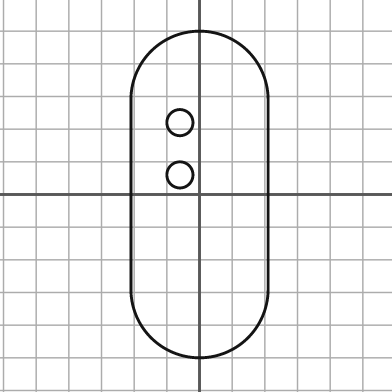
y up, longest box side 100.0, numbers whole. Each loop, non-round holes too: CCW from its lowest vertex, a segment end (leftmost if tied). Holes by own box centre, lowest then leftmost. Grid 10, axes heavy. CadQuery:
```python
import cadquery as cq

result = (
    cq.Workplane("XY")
    .moveTo(-21.0, -29.0)
    .threePointArc((0.0, -50.0), (21.0, -29.0))
    .lineTo(21.0, 29.0)
    .threePointArc((0.0, 50.0), (-21.0, 29.0))
    .close()
    .moveTo(-6.0, 6.0)
    .circle(4.0)
    .moveTo(-6.0, 22.0)
    .circle(4.0)
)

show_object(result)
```